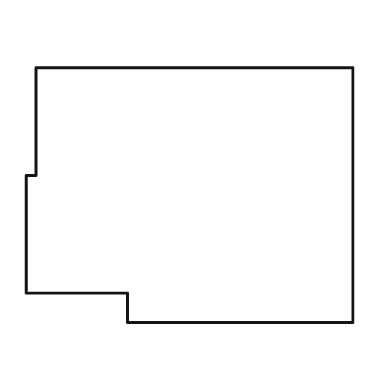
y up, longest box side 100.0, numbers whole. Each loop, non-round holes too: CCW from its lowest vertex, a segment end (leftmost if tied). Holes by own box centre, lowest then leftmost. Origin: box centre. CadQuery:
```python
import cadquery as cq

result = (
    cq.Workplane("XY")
    .moveTo(-19.0, -39.0)
    .lineTo(50.0, -39.0)
    .lineTo(50.0, 39.0)
    .lineTo(-47.0, 39.0)
    .lineTo(-47.0, 6.0)
    .lineTo(-50.0, 6.0)
    .lineTo(-50.0, -30.0)
    .lineTo(-19.0, -30.0)
    .close()
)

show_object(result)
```